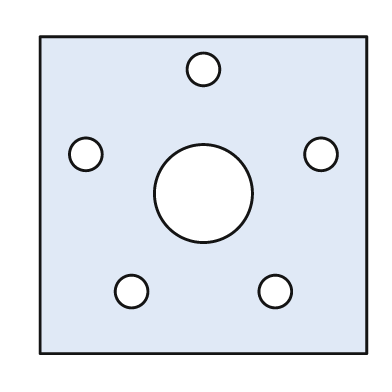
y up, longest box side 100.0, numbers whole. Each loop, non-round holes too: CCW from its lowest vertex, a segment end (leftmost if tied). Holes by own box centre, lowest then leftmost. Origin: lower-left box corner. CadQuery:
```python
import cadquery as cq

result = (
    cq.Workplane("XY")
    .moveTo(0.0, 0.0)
    .lineTo(100.0, 0.0)
    .lineTo(100.0, 97.0)
    .lineTo(0.0, 97.0)
    .close()
    .moveTo(28.0, 19.0)
    .circle(5.0)
    .moveTo(72.0, 19.0)
    .circle(5.0)
    .moveTo(50.0, 49.0)
    .circle(15.0)
    .moveTo(14.0, 61.0)
    .circle(5.0)
    .moveTo(86.0, 61.0)
    .circle(5.0)
    .moveTo(50.0, 87.0)
    .circle(5.0)
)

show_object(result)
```